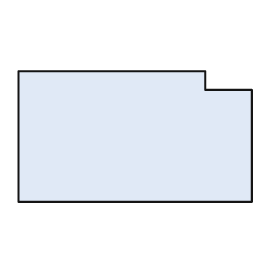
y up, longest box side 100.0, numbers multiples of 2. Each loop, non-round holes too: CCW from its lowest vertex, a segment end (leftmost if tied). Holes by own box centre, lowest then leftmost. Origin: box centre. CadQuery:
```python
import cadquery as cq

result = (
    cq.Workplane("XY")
    .moveTo(-50.0, -28.0)
    .lineTo(50.0, -28.0)
    .lineTo(50.0, 20.0)
    .lineTo(30.0, 20.0)
    .lineTo(30.0, 28.0)
    .lineTo(-50.0, 28.0)
    .close()
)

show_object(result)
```